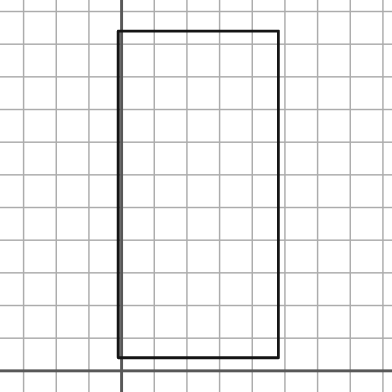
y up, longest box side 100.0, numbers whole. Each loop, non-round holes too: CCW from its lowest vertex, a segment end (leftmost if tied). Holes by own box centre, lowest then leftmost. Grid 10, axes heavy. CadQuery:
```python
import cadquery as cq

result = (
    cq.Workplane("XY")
    .moveTo(-1.0, 4.0)
    .lineTo(48.0, 4.0)
    .lineTo(48.0, 104.0)
    .lineTo(-1.0, 104.0)
    .close()
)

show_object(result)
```